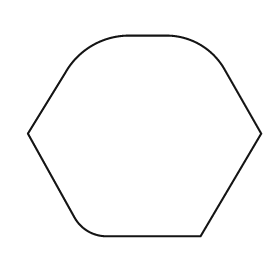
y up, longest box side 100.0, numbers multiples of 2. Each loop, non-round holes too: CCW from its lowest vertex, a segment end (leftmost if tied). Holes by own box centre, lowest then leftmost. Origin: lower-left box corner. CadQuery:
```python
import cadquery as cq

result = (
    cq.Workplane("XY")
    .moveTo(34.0, 0.0)
    .lineTo(74.0, 0.0)
    .lineTo(100.0, 44.0)
    .lineTo(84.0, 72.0)
    .threePointArc((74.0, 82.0), (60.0, 86.0))
    .lineTo(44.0, 86.0)
    .threePointArc((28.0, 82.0), (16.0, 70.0))
    .lineTo(0.0, 44.0)
    .lineTo(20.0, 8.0)
    .threePointArc((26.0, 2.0), (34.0, 0.0))
    .close()
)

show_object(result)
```